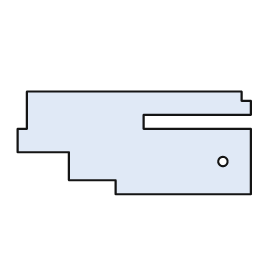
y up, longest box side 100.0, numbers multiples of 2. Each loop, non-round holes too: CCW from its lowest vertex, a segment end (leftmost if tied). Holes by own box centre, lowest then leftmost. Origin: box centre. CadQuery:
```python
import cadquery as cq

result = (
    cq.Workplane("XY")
    .moveTo(-8.0, -22.0)
    .lineTo(50.0, -22.0)
    .lineTo(50.0, 6.0)
    .lineTo(4.0, 6.0)
    .lineTo(4.0, 12.0)
    .lineTo(50.0, 12.0)
    .lineTo(50.0, 18.0)
    .lineTo(46.0, 18.0)
    .lineTo(46.0, 22.0)
    .lineTo(-46.0, 22.0)
    .lineTo(-46.0, 6.0)
    .lineTo(-50.0, 6.0)
    .lineTo(-50.0, -4.0)
    .lineTo(-28.0, -4.0)
    .lineTo(-28.0, -16.0)
    .lineTo(-8.0, -16.0)
    .close()
    .moveTo(38.0, -8.0)
    .circle(2.0)
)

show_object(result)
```